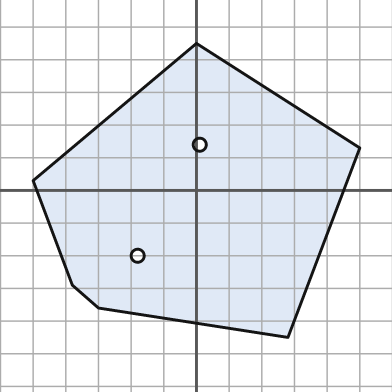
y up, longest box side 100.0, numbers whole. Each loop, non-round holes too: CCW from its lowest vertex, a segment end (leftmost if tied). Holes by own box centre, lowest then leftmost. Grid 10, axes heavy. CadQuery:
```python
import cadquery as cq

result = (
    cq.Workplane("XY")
    .moveTo(28.0, -45.0)
    .lineTo(50.0, 13.0)
    .lineTo(0.0, 45.0)
    .lineTo(-50.0, 3.0)
    .lineTo(-38.0, -29.0)
    .lineTo(-30.0, -36.0)
    .close()
    .moveTo(-18.0, -20.0)
    .circle(2.0)
    .moveTo(1.0, 14.0)
    .circle(2.0)
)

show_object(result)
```